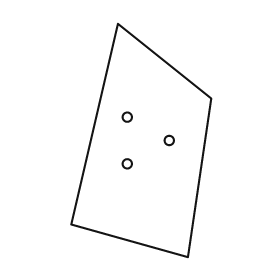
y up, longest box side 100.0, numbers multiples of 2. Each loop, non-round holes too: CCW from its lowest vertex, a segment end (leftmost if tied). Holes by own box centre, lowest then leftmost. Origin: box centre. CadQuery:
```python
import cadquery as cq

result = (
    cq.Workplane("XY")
    .moveTo(20.0, -50.0)
    .lineTo(30.0, 18.0)
    .lineTo(-10.0, 50.0)
    .lineTo(-30.0, -36.0)
    .close()
    .moveTo(-6.0, -10.0)
    .circle(2.0)
    .moveTo(12.0, 0.0)
    .circle(2.0)
    .moveTo(-6.0, 10.0)
    .circle(2.0)
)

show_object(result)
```